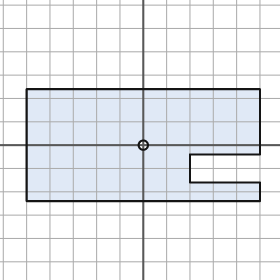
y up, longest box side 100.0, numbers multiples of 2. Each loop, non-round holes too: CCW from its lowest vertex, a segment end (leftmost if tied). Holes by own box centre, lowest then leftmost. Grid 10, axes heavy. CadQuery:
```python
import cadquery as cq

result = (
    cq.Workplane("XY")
    .moveTo(-50.0, -24.0)
    .lineTo(50.0, -24.0)
    .lineTo(50.0, -16.0)
    .lineTo(20.0, -16.0)
    .lineTo(20.0, -4.0)
    .lineTo(50.0, -4.0)
    .lineTo(50.0, 24.0)
    .lineTo(-50.0, 24.0)
    .close()
    .moveTo(0.0, 0.0)
    .circle(2.0)
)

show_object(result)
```